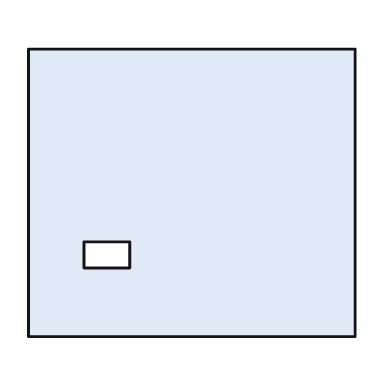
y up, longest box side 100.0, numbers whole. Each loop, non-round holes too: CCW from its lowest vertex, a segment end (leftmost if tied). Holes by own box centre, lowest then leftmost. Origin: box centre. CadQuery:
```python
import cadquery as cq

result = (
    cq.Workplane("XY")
    .moveTo(-50.0, -44.0)
    .lineTo(50.0, -44.0)
    .lineTo(50.0, 44.0)
    .lineTo(-50.0, 44.0)
    .close()
    .moveTo(-33.0, -23.0)
    .lineTo(-19.0, -23.0)
    .lineTo(-19.0, -15.0)
    .lineTo(-33.0, -15.0)
    .close()
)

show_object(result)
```